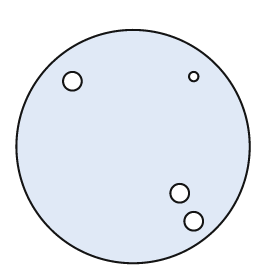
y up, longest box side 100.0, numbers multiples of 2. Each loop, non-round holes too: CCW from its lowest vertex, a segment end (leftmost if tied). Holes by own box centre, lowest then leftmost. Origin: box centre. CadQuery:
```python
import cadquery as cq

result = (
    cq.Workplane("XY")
    .moveTo(0.0, 0.0)
    .circle(50.0)
    .moveTo(26.0, -32.0)
    .circle(4.0)
    .moveTo(20.0, -20.0)
    .circle(4.0)
    .moveTo(-26.0, 28.0)
    .circle(4.0)
    .moveTo(26.0, 30.0)
    .circle(2.0)
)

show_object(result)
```